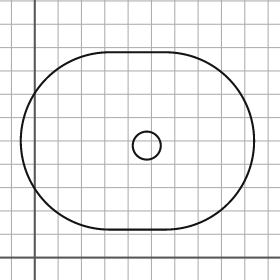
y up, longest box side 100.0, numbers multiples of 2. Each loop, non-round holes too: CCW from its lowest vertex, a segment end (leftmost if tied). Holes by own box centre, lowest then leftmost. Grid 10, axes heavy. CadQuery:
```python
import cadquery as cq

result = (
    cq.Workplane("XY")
    .moveTo(32.0, 12.0)
    .lineTo(56.0, 12.0)
    .threePointArc((94.0, 50.0), (56.0, 88.0))
    .lineTo(32.0, 88.0)
    .threePointArc((-6.0, 50.0), (32.0, 12.0))
    .close()
    .moveTo(48.0, 48.0)
    .circle(6.0)
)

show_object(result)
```